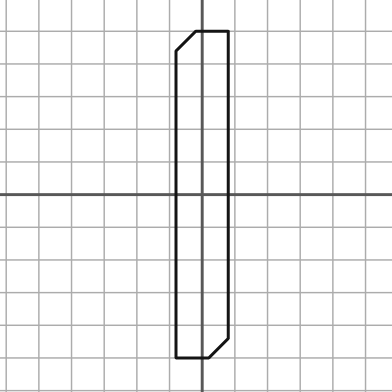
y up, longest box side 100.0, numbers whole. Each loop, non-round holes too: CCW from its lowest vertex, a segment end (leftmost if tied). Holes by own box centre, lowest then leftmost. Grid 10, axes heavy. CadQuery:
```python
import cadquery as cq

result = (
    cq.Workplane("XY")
    .moveTo(-8.0, -50.0)
    .lineTo(2.0, -50.0)
    .lineTo(8.0, -44.0)
    .lineTo(8.0, 50.0)
    .lineTo(-2.0, 50.0)
    .lineTo(-8.0, 44.0)
    .close()
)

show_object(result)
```